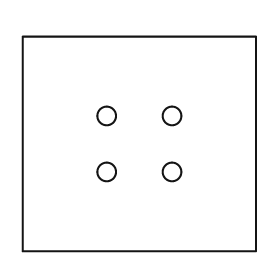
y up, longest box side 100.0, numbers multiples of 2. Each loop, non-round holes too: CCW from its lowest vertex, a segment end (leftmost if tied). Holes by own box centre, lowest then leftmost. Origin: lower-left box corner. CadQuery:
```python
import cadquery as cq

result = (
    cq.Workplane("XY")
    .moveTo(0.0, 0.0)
    .lineTo(100.0, 0.0)
    .lineTo(100.0, 92.0)
    .lineTo(0.0, 92.0)
    .close()
    .moveTo(36.0, 34.0)
    .circle(4.0)
    .moveTo(64.0, 34.0)
    .circle(4.0)
    .moveTo(36.0, 58.0)
    .circle(4.0)
    .moveTo(64.0, 58.0)
    .circle(4.0)
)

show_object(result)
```